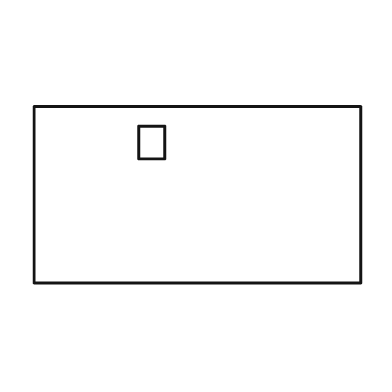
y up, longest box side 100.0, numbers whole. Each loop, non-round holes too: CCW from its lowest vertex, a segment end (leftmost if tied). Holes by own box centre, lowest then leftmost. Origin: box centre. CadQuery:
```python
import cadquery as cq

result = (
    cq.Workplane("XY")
    .moveTo(-50.0, -27.0)
    .lineTo(50.0, -27.0)
    .lineTo(50.0, 27.0)
    .lineTo(-50.0, 27.0)
    .close()
    .moveTo(-18.0, 11.0)
    .lineTo(-10.0, 11.0)
    .lineTo(-10.0, 21.0)
    .lineTo(-18.0, 21.0)
    .close()
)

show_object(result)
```